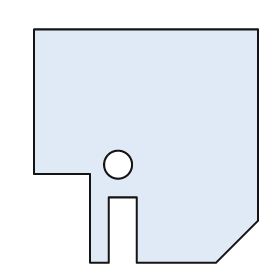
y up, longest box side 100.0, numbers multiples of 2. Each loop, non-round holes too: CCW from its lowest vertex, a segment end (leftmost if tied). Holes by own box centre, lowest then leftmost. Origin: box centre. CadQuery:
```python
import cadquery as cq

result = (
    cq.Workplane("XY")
    .moveTo(-24.0, -50.0)
    .lineTo(-16.0, -50.0)
    .lineTo(-16.0, -22.0)
    .lineTo(-4.0, -22.0)
    .lineTo(-4.0, -50.0)
    .lineTo(30.0, -50.0)
    .lineTo(48.0, -32.0)
    .lineTo(48.0, 50.0)
    .lineTo(-48.0, 50.0)
    .lineTo(-48.0, -12.0)
    .lineTo(-24.0, -12.0)
    .close()
    .moveTo(-12.0, -8.0)
    .circle(6.0)
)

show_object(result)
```